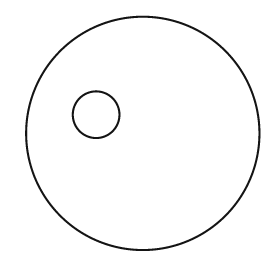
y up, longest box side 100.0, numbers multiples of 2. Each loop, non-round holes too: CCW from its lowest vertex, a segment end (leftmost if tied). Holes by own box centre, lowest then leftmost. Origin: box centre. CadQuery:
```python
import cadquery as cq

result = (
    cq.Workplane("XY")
    .moveTo(0.0, 0.0)
    .circle(50.0)
    .moveTo(-20.0, 8.0)
    .circle(10.0)
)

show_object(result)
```